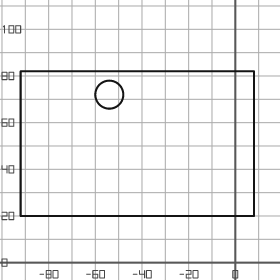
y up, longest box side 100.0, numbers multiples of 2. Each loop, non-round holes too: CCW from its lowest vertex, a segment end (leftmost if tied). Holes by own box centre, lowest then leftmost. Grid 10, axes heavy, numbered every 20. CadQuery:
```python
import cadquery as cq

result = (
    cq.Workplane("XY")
    .moveTo(-92.0, 20.0)
    .lineTo(8.0, 20.0)
    .lineTo(8.0, 82.0)
    .lineTo(-92.0, 82.0)
    .close()
    .moveTo(-54.0, 72.0)
    .circle(6.0)
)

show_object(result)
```